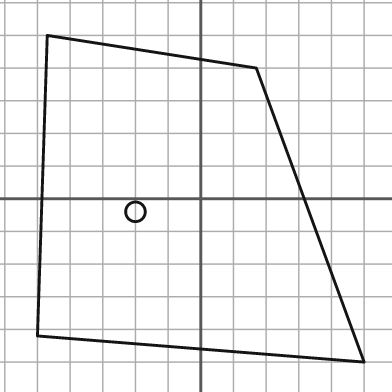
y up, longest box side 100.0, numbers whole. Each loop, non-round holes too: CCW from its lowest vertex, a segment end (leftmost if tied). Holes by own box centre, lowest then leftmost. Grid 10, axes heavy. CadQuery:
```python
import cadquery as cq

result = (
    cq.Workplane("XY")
    .moveTo(50.0, -50.0)
    .lineTo(17.0, 40.0)
    .lineTo(-47.0, 50.0)
    .lineTo(-50.0, -42.0)
    .close()
    .moveTo(-20.0, -4.0)
    .circle(3.0)
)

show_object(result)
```